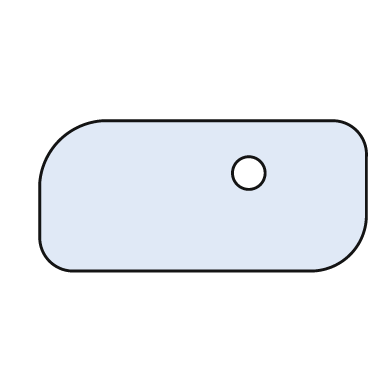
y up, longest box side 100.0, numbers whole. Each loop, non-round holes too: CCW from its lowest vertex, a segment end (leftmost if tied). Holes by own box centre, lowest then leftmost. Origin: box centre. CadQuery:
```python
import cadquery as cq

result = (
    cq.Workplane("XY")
    .moveTo(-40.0, -23.0)
    .lineTo(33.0, -23.0)
    .threePointArc((45.0, -18.0), (50.0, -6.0))
    .lineTo(50.0, 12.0)
    .threePointArc((47.0, 20.0), (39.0, 23.0))
    .lineTo(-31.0, 23.0)
    .threePointArc((-44.0, 17.0), (-50.0, 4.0))
    .lineTo(-50.0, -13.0)
    .threePointArc((-47.0, -20.0), (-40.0, -23.0))
    .close()
    .moveTo(14.0, 7.0)
    .circle(5.0)
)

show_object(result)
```